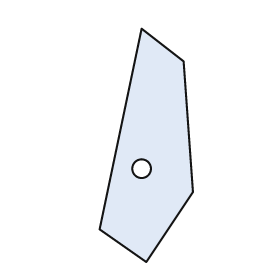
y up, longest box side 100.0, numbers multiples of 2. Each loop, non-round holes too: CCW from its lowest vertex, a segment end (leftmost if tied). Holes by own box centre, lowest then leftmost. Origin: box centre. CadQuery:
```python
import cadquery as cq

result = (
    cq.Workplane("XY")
    .moveTo(0.0, -50.0)
    .lineTo(20.0, -20.0)
    .lineTo(16.0, 36.0)
    .lineTo(-2.0, 50.0)
    .lineTo(-20.0, -36.0)
    .close()
    .moveTo(-2.0, -10.0)
    .circle(4.0)
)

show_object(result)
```